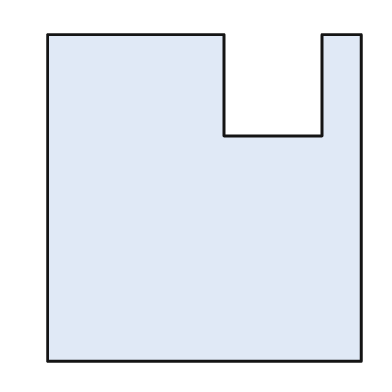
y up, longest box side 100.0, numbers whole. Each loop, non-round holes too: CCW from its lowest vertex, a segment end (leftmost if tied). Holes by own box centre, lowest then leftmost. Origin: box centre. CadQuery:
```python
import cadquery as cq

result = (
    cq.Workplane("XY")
    .moveTo(-48.0, -50.0)
    .lineTo(48.0, -50.0)
    .lineTo(48.0, 50.0)
    .lineTo(36.0, 50.0)
    .lineTo(36.0, 19.0)
    .lineTo(6.0, 19.0)
    .lineTo(6.0, 50.0)
    .lineTo(-48.0, 50.0)
    .close()
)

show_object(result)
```